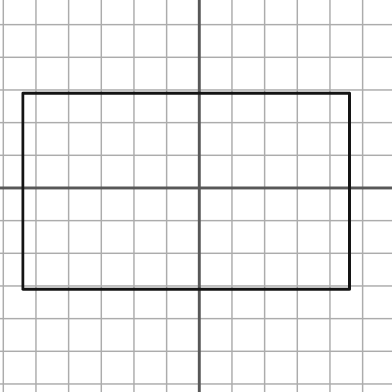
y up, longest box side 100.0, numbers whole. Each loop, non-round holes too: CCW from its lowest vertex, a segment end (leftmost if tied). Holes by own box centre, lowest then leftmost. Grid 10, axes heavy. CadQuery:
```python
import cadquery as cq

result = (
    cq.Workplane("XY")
    .moveTo(-54.0, -31.0)
    .lineTo(46.0, -31.0)
    .lineTo(46.0, 29.0)
    .lineTo(-54.0, 29.0)
    .close()
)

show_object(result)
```